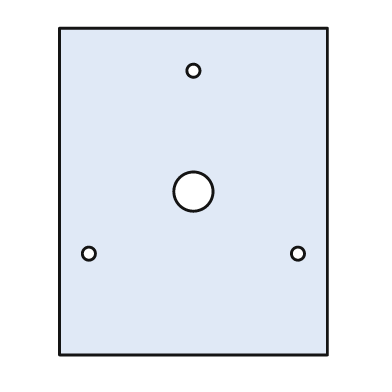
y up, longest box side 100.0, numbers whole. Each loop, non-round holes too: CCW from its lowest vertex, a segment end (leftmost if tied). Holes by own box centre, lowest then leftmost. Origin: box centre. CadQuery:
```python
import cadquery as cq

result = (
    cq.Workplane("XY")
    .moveTo(-41.0, -50.0)
    .lineTo(41.0, -50.0)
    .lineTo(41.0, 50.0)
    .lineTo(-41.0, 50.0)
    .close()
    .moveTo(-32.0, -19.0)
    .circle(2.0)
    .moveTo(32.0, -19.0)
    .circle(2.0)
    .moveTo(0.0, 0.0)
    .circle(6.0)
    .moveTo(0.0, 37.0)
    .circle(2.0)
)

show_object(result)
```